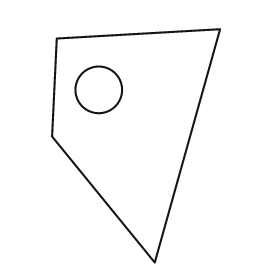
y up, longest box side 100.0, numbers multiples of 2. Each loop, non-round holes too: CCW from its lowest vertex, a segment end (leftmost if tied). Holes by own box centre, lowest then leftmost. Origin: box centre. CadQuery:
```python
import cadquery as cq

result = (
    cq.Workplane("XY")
    .moveTo(8.0, -50.0)
    .lineTo(36.0, 50.0)
    .lineTo(-34.0, 46.0)
    .lineTo(-36.0, 4.0)
    .close()
    .moveTo(-16.0, 24.0)
    .circle(10.0)
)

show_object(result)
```